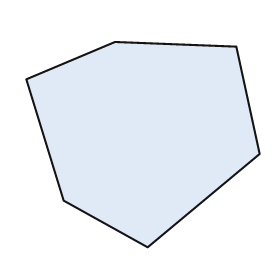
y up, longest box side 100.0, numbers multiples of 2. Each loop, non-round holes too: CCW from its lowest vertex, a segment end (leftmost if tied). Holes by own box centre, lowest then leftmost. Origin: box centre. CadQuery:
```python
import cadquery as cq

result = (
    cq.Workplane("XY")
    .moveTo(2.0, -44.0)
    .lineTo(50.0, -4.0)
    .lineTo(40.0, 42.0)
    .lineTo(-12.0, 44.0)
    .lineTo(-50.0, 28.0)
    .lineTo(-34.0, -24.0)
    .close()
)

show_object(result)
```